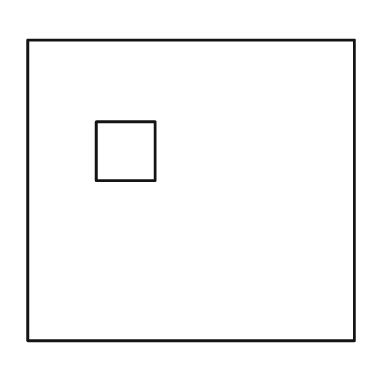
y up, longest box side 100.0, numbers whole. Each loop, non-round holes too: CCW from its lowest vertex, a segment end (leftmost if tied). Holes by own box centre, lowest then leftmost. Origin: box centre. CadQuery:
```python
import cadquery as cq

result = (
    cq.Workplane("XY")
    .moveTo(-50.0, -46.0)
    .lineTo(50.0, -46.0)
    .lineTo(50.0, 46.0)
    .lineTo(-50.0, 46.0)
    .close()
    .moveTo(-29.0, 3.0)
    .lineTo(-11.0, 3.0)
    .lineTo(-11.0, 21.0)
    .lineTo(-29.0, 21.0)
    .close()
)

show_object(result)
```